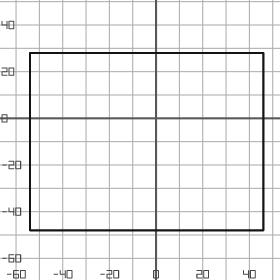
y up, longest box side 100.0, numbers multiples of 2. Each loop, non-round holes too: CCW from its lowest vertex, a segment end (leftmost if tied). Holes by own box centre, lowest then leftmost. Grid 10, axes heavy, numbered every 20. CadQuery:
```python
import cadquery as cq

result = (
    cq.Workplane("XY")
    .moveTo(-54.0, -48.0)
    .lineTo(46.0, -48.0)
    .lineTo(46.0, 28.0)
    .lineTo(-54.0, 28.0)
    .close()
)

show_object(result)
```